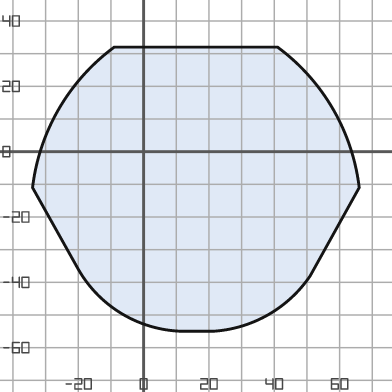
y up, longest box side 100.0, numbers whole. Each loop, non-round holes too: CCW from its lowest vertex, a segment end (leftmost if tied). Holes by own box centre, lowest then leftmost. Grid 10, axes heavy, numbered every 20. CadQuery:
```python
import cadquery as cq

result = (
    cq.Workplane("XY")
    .moveTo(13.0, -55.0)
    .lineTo(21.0, -55.0)
    .threePointArc((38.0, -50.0), (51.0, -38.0))
    .lineTo(66.0, -11.0)
    .threePointArc((58.0, 13.0), (41.0, 32.0))
    .lineTo(-9.0, 32.0)
    .threePointArc((-26.0, 13.0), (-34.0, -11.0))
    .lineTo(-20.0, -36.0)
    .threePointArc((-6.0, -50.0), (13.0, -55.0))
    .close()
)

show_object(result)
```